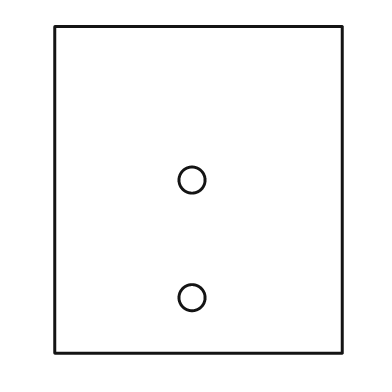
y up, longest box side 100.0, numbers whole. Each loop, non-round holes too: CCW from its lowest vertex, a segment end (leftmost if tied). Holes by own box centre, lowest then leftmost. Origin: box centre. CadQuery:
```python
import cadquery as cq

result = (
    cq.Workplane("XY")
    .moveTo(-44.0, -50.0)
    .lineTo(44.0, -50.0)
    .lineTo(44.0, 50.0)
    .lineTo(-44.0, 50.0)
    .close()
    .moveTo(-2.0, -33.0)
    .circle(4.0)
    .moveTo(-2.0, 3.0)
    .circle(4.0)
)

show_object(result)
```